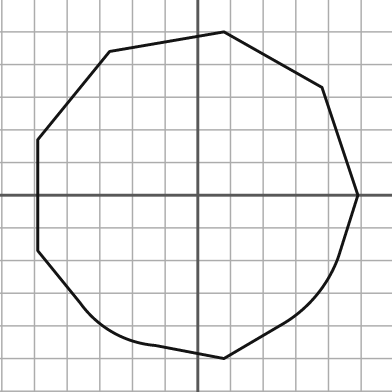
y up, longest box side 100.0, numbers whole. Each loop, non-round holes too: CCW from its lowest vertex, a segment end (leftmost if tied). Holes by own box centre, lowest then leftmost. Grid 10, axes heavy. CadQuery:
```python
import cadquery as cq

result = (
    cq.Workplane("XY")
    .moveTo(8.0, -50.0)
    .lineTo(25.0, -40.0)
    .threePointArc((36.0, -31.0), (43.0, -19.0))
    .lineTo(49.0, 0.0)
    .lineTo(38.0, 33.0)
    .lineTo(8.0, 50.0)
    .lineTo(-27.0, 44.0)
    .lineTo(-49.0, 17.0)
    .lineTo(-49.0, -17.0)
    .lineTo(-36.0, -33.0)
    .threePointArc((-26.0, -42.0), (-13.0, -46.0))
    .close()
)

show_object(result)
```